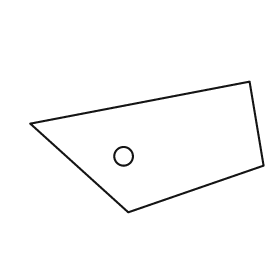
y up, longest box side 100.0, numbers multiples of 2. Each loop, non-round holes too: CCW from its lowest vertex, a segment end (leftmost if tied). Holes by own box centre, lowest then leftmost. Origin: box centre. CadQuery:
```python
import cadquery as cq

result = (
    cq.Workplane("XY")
    .moveTo(-8.0, -28.0)
    .lineTo(50.0, -8.0)
    .lineTo(44.0, 28.0)
    .lineTo(-50.0, 10.0)
    .close()
    .moveTo(-10.0, -4.0)
    .circle(4.0)
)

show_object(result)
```